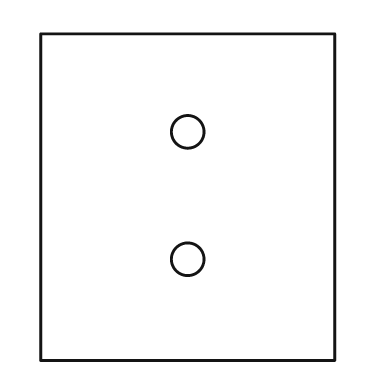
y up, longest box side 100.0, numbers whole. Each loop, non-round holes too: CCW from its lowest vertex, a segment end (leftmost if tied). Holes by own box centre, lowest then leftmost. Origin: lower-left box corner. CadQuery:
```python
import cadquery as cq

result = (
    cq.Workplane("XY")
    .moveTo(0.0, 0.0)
    .lineTo(90.0, 0.0)
    .lineTo(90.0, 100.0)
    .lineTo(0.0, 100.0)
    .close()
    .moveTo(45.0, 31.0)
    .circle(5.0)
    .moveTo(45.0, 70.0)
    .circle(5.0)
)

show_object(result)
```